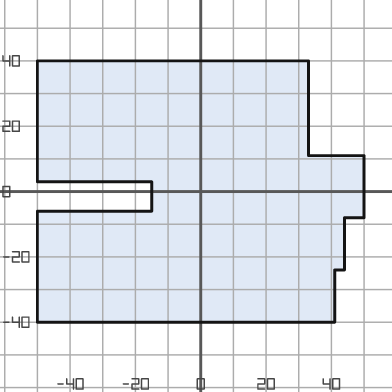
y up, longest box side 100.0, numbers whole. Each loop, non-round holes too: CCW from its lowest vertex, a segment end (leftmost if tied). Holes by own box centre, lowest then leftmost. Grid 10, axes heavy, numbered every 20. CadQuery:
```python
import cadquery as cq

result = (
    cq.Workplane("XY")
    .moveTo(-50.0, -40.0)
    .lineTo(41.0, -40.0)
    .lineTo(41.0, -24.0)
    .lineTo(44.0, -24.0)
    .lineTo(44.0, -8.0)
    .lineTo(50.0, -8.0)
    .lineTo(50.0, 11.0)
    .lineTo(33.0, 11.0)
    .lineTo(33.0, 40.0)
    .lineTo(-50.0, 40.0)
    .lineTo(-50.0, 3.0)
    .lineTo(-15.0, 3.0)
    .lineTo(-15.0, -6.0)
    .lineTo(-50.0, -6.0)
    .close()
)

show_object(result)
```